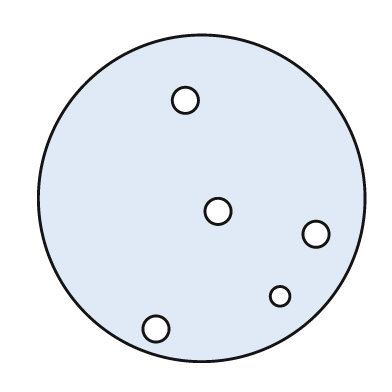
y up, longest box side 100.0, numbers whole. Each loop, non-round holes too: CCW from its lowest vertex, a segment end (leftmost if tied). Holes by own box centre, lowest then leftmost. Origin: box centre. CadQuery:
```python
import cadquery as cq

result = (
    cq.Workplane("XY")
    .moveTo(0.0, 0.0)
    .circle(50.0)
    .moveTo(-14.0, -40.0)
    .circle(4.0)
    .moveTo(24.0, -30.0)
    .circle(3.0)
    .moveTo(35.0, -11.0)
    .circle(4.0)
    .moveTo(5.0, -4.0)
    .circle(4.0)
    .moveTo(-5.0, 30.0)
    .circle(4.0)
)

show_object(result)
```